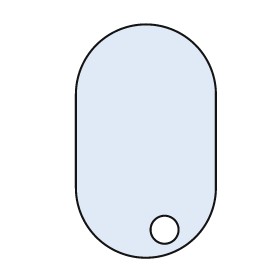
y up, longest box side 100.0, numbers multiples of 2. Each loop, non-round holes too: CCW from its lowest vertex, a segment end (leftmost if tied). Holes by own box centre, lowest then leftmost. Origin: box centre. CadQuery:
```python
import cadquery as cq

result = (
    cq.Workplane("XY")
    .moveTo(-30.0, -20.0)
    .threePointArc((0.0, -50.0), (30.0, -20.0))
    .lineTo(30.0, 20.0)
    .threePointArc((0.0, 50.0), (-30.0, 20.0))
    .close()
    .moveTo(8.0, -38.0)
    .circle(6.0)
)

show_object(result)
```